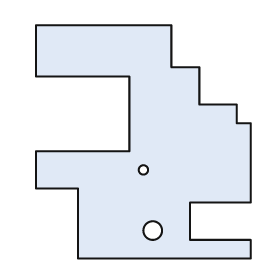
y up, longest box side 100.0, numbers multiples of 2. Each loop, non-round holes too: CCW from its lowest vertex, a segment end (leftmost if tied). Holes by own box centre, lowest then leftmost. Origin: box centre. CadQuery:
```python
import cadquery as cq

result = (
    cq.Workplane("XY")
    .moveTo(-28.0, -50.0)
    .lineTo(46.0, -50.0)
    .lineTo(46.0, -42.0)
    .lineTo(20.0, -42.0)
    .lineTo(20.0, -26.0)
    .lineTo(46.0, -26.0)
    .lineTo(46.0, 8.0)
    .lineTo(40.0, 8.0)
    .lineTo(40.0, 16.0)
    .lineTo(24.0, 16.0)
    .lineTo(24.0, 32.0)
    .lineTo(12.0, 32.0)
    .lineTo(12.0, 50.0)
    .lineTo(-46.0, 50.0)
    .lineTo(-46.0, 28.0)
    .lineTo(-6.0, 28.0)
    .lineTo(-6.0, -4.0)
    .lineTo(-46.0, -4.0)
    .lineTo(-46.0, -20.0)
    .lineTo(-28.0, -20.0)
    .close()
    .moveTo(4.0, -38.0)
    .circle(4.0)
    .moveTo(0.0, -12.0)
    .circle(2.0)
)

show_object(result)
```